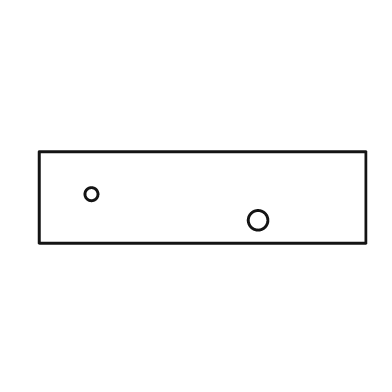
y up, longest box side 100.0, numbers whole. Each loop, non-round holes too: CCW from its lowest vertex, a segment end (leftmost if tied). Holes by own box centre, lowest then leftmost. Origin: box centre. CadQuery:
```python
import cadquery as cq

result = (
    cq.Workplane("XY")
    .moveTo(-50.0, -14.0)
    .lineTo(50.0, -14.0)
    .lineTo(50.0, 14.0)
    .lineTo(-50.0, 14.0)
    .close()
    .moveTo(17.0, -7.0)
    .circle(3.0)
    .moveTo(-34.0, 1.0)
    .circle(2.0)
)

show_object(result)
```